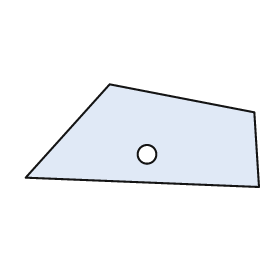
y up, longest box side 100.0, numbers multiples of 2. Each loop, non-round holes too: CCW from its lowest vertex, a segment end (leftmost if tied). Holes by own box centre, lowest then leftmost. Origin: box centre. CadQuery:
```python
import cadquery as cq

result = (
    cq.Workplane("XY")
    .moveTo(50.0, -22.0)
    .lineTo(48.0, 10.0)
    .lineTo(-14.0, 22.0)
    .lineTo(-50.0, -18.0)
    .close()
    .moveTo(2.0, -8.0)
    .circle(4.0)
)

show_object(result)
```